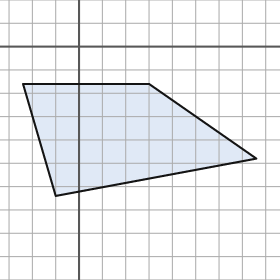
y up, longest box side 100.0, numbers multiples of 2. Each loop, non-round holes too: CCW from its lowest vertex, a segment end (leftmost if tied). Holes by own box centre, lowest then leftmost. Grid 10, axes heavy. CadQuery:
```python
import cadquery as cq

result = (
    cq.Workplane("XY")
    .moveTo(-10.0, -64.0)
    .lineTo(76.0, -48.0)
    .lineTo(30.0, -16.0)
    .lineTo(-24.0, -16.0)
    .close()
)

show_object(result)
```